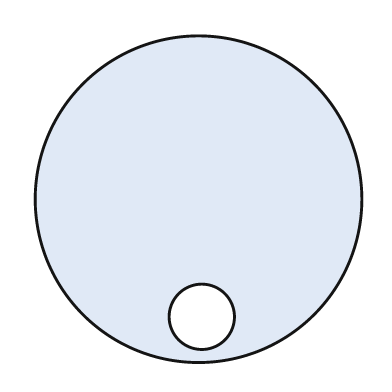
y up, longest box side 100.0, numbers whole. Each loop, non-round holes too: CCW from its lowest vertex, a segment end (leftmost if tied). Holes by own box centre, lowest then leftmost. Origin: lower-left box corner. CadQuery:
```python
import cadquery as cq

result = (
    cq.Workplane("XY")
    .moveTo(50.0, 50.0)
    .circle(50.0)
    .moveTo(51.0, 14.0)
    .circle(10.0)
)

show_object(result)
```